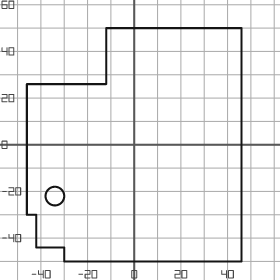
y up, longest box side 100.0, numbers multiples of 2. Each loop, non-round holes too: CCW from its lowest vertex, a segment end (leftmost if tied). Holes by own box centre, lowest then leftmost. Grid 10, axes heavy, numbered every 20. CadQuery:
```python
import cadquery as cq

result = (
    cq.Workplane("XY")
    .moveTo(-30.0, -50.0)
    .lineTo(46.0, -50.0)
    .lineTo(46.0, 50.0)
    .lineTo(-12.0, 50.0)
    .lineTo(-12.0, 26.0)
    .lineTo(-46.0, 26.0)
    .lineTo(-46.0, -30.0)
    .lineTo(-42.0, -30.0)
    .lineTo(-42.0, -44.0)
    .lineTo(-30.0, -44.0)
    .close()
    .moveTo(-34.0, -22.0)
    .circle(4.0)
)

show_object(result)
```